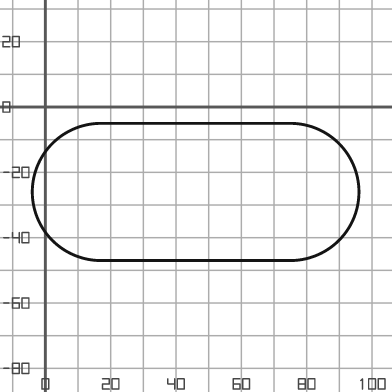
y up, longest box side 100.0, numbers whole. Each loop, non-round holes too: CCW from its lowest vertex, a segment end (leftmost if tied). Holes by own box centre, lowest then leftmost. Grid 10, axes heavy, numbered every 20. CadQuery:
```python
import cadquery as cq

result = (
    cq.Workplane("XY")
    .moveTo(17.0, -47.0)
    .lineTo(75.0, -47.0)
    .threePointArc((96.0, -26.0), (75.0, -5.0))
    .lineTo(17.0, -5.0)
    .threePointArc((-4.0, -26.0), (17.0, -47.0))
    .close()
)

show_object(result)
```